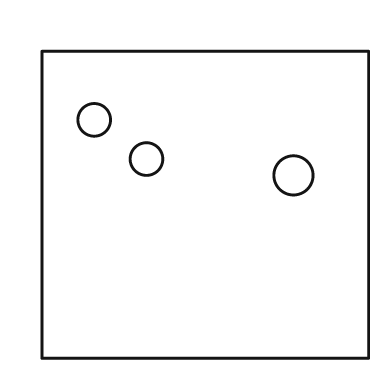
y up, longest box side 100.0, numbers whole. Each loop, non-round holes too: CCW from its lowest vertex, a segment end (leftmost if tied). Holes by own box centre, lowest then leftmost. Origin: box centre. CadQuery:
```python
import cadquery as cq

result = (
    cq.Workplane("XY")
    .moveTo(-50.0, -47.0)
    .lineTo(50.0, -47.0)
    .lineTo(50.0, 47.0)
    .lineTo(-50.0, 47.0)
    .close()
    .moveTo(27.0, 9.0)
    .circle(6.0)
    .moveTo(-18.0, 14.0)
    .circle(5.0)
    .moveTo(-34.0, 26.0)
    .circle(5.0)
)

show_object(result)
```